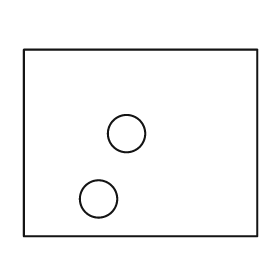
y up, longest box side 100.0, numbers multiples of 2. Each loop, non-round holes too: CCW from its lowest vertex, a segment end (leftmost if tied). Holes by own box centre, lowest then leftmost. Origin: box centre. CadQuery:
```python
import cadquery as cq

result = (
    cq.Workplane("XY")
    .moveTo(-50.0, -40.0)
    .lineTo(50.0, -40.0)
    .lineTo(50.0, 40.0)
    .lineTo(-50.0, 40.0)
    .close()
    .moveTo(-18.0, -24.0)
    .circle(8.0)
    .moveTo(-6.0, 4.0)
    .circle(8.0)
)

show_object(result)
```